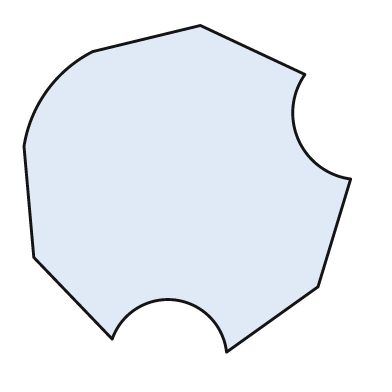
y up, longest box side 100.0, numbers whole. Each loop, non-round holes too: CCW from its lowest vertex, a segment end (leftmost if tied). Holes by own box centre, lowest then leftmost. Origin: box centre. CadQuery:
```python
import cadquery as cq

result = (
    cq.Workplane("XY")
    .moveTo(12.0, -50.0)
    .lineTo(40.0, -30.0)
    .lineTo(50.0, 3.0)
    .threePointArc((34.0, 15.0), (36.0, 35.0))
    .lineTo(4.0, 50.0)
    .lineTo(-29.0, 42.0)
    .threePointArc((-43.0, 30.0), (-50.0, 13.0))
    .lineTo(-47.0, -21.0)
    .lineTo(-23.0, -46.0)
    .threePointArc((-4.0, -34.0), (12.0, -50.0))
    .close()
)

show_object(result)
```